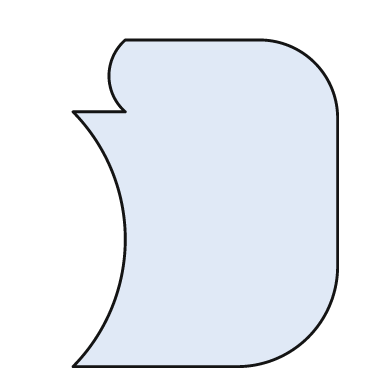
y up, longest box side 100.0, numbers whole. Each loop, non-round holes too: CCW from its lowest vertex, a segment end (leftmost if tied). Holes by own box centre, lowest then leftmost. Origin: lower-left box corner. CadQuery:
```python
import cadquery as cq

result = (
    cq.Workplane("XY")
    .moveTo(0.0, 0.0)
    .lineTo(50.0, 0.0)
    .threePointArc((72.0, 9.0), (81.0, 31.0))
    .lineTo(81.0, 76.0)
    .threePointArc((74.0, 93.0), (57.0, 100.0))
    .lineTo(16.0, 100.0)
    .threePointArc((11.0, 89.0), (16.0, 78.0))
    .lineTo(0.0, 78.0)
    .threePointArc((16.0, 39.0), (0.0, 0.0))
    .close()
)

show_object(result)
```